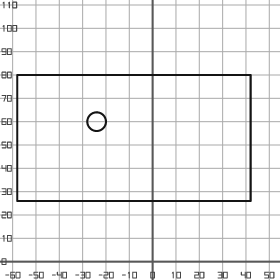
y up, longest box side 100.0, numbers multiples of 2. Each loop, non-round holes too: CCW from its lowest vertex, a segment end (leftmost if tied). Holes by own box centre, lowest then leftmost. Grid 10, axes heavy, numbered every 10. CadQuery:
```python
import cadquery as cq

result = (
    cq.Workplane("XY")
    .moveTo(-58.0, 26.0)
    .lineTo(42.0, 26.0)
    .lineTo(42.0, 80.0)
    .lineTo(-58.0, 80.0)
    .close()
    .moveTo(-24.0, 60.0)
    .circle(4.0)
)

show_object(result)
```